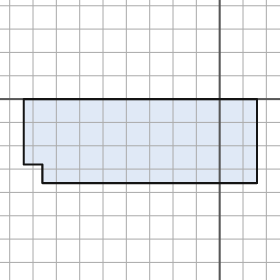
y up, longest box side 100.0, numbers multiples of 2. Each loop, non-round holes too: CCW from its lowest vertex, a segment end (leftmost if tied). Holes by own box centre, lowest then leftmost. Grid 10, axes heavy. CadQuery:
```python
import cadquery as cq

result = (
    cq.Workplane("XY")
    .moveTo(-76.0, -36.0)
    .lineTo(16.0, -36.0)
    .lineTo(16.0, 0.0)
    .lineTo(-84.0, 0.0)
    .lineTo(-84.0, -28.0)
    .lineTo(-76.0, -28.0)
    .close()
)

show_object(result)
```